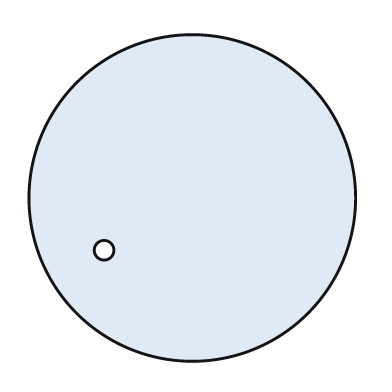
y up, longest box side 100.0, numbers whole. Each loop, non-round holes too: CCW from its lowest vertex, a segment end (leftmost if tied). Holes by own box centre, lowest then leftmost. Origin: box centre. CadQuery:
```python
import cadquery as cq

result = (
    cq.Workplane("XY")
    .moveTo(0.0, 0.0)
    .circle(50.0)
    .moveTo(-27.0, -16.0)
    .circle(3.0)
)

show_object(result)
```